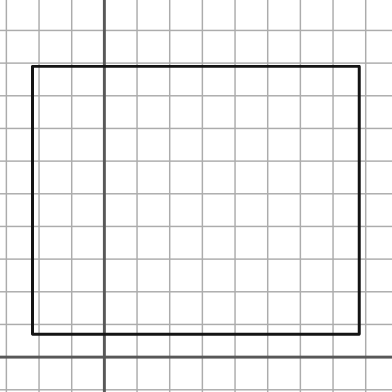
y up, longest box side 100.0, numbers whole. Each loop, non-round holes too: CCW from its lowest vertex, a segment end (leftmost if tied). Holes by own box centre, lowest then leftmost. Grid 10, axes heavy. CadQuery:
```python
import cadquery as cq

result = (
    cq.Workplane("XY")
    .moveTo(-22.0, 7.0)
    .lineTo(78.0, 7.0)
    .lineTo(78.0, 89.0)
    .lineTo(-22.0, 89.0)
    .close()
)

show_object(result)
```